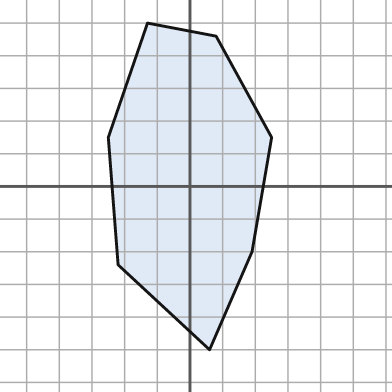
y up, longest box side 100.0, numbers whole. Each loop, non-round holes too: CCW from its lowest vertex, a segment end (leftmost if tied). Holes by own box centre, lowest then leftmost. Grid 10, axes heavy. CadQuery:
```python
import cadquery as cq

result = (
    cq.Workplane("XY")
    .moveTo(6.0, -50.0)
    .lineTo(19.0, -20.0)
    .lineTo(25.0, 15.0)
    .lineTo(8.0, 46.0)
    .lineTo(-13.0, 50.0)
    .lineTo(-25.0, 15.0)
    .lineTo(-22.0, -24.0)
    .close()
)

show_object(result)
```